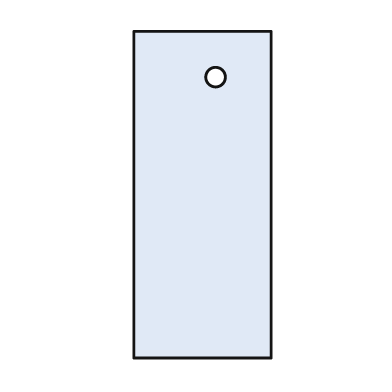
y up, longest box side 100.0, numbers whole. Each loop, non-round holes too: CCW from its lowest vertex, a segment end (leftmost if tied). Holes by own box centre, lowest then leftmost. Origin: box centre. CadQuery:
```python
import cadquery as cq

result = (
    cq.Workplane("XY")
    .moveTo(-21.0, -50.0)
    .lineTo(21.0, -50.0)
    .lineTo(21.0, 50.0)
    .lineTo(-21.0, 50.0)
    .close()
    .moveTo(4.0, 36.0)
    .circle(3.0)
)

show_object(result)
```